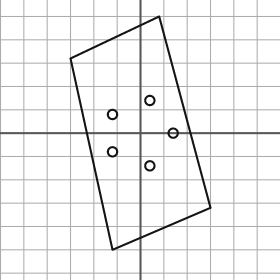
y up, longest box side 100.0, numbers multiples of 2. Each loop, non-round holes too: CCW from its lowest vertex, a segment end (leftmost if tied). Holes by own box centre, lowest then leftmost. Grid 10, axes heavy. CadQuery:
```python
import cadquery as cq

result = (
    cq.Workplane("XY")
    .moveTo(-12.0, -50.0)
    .lineTo(30.0, -32.0)
    .lineTo(8.0, 50.0)
    .lineTo(-30.0, 32.0)
    .close()
    .moveTo(4.0, -14.0)
    .circle(2.0)
    .moveTo(-12.0, -8.0)
    .circle(2.0)
    .moveTo(14.0, 0.0)
    .circle(2.0)
    .moveTo(-12.0, 8.0)
    .circle(2.0)
    .moveTo(4.0, 14.0)
    .circle(2.0)
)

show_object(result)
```